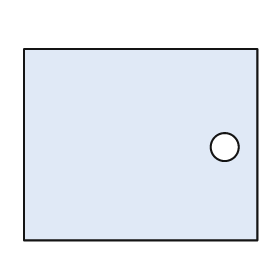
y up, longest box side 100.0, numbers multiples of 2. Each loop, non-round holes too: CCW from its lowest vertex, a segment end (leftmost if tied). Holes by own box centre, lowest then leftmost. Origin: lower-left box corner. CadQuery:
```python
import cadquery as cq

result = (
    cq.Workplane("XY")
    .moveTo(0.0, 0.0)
    .lineTo(100.0, 0.0)
    .lineTo(100.0, 82.0)
    .lineTo(0.0, 82.0)
    .close()
    .moveTo(86.0, 40.0)
    .circle(6.0)
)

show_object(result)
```